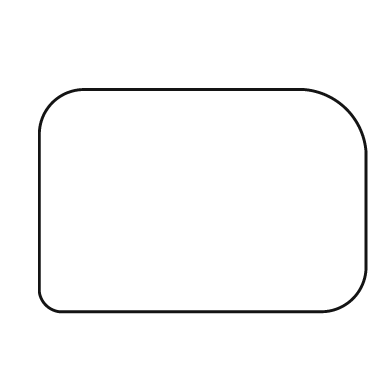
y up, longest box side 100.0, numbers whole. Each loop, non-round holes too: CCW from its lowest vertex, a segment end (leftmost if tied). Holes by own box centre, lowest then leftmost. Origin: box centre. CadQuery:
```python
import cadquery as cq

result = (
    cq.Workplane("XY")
    .moveTo(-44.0, -34.0)
    .lineTo(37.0, -34.0)
    .threePointArc((46.0, -30.0), (50.0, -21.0))
    .lineTo(50.0, 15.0)
    .threePointArc((44.0, 28.0), (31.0, 34.0))
    .lineTo(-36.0, 34.0)
    .threePointArc((-46.0, 30.0), (-50.0, 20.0))
    .lineTo(-50.0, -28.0)
    .threePointArc((-48.0, -32.0), (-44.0, -34.0))
    .close()
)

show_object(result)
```